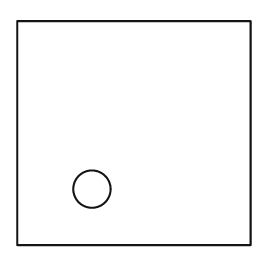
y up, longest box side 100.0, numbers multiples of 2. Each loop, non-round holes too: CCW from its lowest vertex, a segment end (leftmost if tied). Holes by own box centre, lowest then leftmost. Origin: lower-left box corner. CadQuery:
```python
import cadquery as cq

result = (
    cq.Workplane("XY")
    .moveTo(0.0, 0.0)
    .lineTo(100.0, 0.0)
    .lineTo(100.0, 96.0)
    .lineTo(0.0, 96.0)
    .close()
    .moveTo(32.0, 24.0)
    .circle(8.0)
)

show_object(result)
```